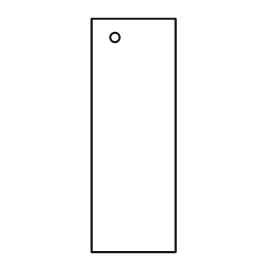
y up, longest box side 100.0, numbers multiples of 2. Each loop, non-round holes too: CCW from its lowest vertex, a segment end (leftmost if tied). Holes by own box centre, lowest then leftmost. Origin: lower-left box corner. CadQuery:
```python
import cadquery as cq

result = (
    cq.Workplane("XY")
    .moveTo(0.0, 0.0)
    .lineTo(36.0, 0.0)
    .lineTo(36.0, 100.0)
    .lineTo(0.0, 100.0)
    .close()
    .moveTo(10.0, 92.0)
    .circle(2.0)
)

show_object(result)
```